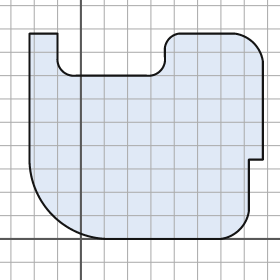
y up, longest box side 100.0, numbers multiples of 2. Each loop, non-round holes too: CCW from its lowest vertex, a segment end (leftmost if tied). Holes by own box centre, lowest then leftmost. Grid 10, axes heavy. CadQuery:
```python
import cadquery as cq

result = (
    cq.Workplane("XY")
    .moveTo(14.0, 0.0)
    .lineTo(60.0, 0.0)
    .threePointArc((68.0, 4.0), (72.0, 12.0))
    .lineTo(72.0, 34.0)
    .lineTo(78.0, 34.0)
    .lineTo(78.0, 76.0)
    .threePointArc((74.0, 84.0), (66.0, 88.0))
    .lineTo(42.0, 88.0)
    .threePointArc((38.0, 86.0), (36.0, 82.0))
    .lineTo(36.0, 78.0)
    .threePointArc((34.0, 72.0), (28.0, 70.0))
    .lineTo(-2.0, 70.0)
    .threePointArc((-8.0, 72.0), (-10.0, 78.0))
    .lineTo(-10.0, 88.0)
    .lineTo(-22.0, 88.0)
    .lineTo(-22.0, 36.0)
    .threePointArc((-12.0, 10.0), (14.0, 0.0))
    .close()
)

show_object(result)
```